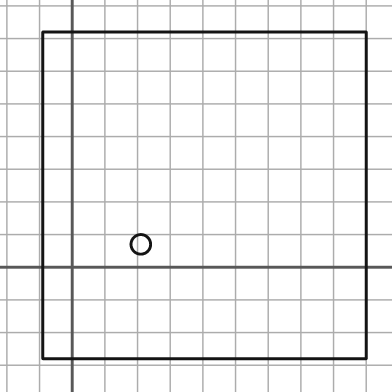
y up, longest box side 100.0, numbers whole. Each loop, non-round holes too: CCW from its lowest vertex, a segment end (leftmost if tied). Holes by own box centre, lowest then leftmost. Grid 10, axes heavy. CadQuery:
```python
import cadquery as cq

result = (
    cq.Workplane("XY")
    .moveTo(-9.0, -28.0)
    .lineTo(90.0, -28.0)
    .lineTo(90.0, 72.0)
    .lineTo(-9.0, 72.0)
    .close()
    .moveTo(21.0, 7.0)
    .circle(3.0)
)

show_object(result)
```